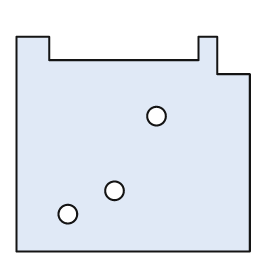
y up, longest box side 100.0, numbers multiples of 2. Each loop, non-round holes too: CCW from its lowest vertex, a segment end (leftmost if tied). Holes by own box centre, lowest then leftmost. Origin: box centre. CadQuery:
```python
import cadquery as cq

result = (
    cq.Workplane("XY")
    .moveTo(-50.0, -46.0)
    .lineTo(50.0, -46.0)
    .lineTo(50.0, 30.0)
    .lineTo(36.0, 30.0)
    .lineTo(36.0, 46.0)
    .lineTo(28.0, 46.0)
    .lineTo(28.0, 36.0)
    .lineTo(-36.0, 36.0)
    .lineTo(-36.0, 46.0)
    .lineTo(-50.0, 46.0)
    .close()
    .moveTo(-28.0, -30.0)
    .circle(4.0)
    .moveTo(-8.0, -20.0)
    .circle(4.0)
    .moveTo(10.0, 12.0)
    .circle(4.0)
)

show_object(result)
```